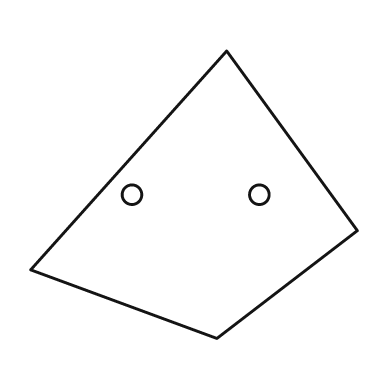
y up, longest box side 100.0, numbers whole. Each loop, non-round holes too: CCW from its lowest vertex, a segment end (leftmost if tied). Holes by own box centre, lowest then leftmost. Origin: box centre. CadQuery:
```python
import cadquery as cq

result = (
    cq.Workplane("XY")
    .moveTo(7.0, -44.0)
    .lineTo(50.0, -11.0)
    .lineTo(10.0, 44.0)
    .lineTo(-50.0, -23.0)
    .close()
    .moveTo(-19.0, 0.0)
    .circle(3.0)
    .moveTo(20.0, 0.0)
    .circle(3.0)
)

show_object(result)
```